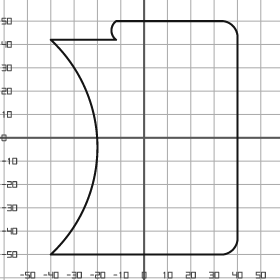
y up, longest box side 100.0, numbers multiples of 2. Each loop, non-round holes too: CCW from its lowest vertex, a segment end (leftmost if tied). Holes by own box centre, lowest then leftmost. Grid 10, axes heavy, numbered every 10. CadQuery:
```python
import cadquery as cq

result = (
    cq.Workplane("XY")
    .moveTo(-40.0, -50.0)
    .lineTo(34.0, -50.0)
    .threePointArc((38.0, -48.0), (40.0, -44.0))
    .lineTo(40.0, 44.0)
    .threePointArc((38.0, 48.0), (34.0, 50.0))
    .lineTo(-12.0, 50.0)
    .threePointArc((-14.0, 46.0), (-12.0, 42.0))
    .lineTo(-40.0, 42.0)
    .threePointArc((-20.0, -4.0), (-40.0, -50.0))
    .close()
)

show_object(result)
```